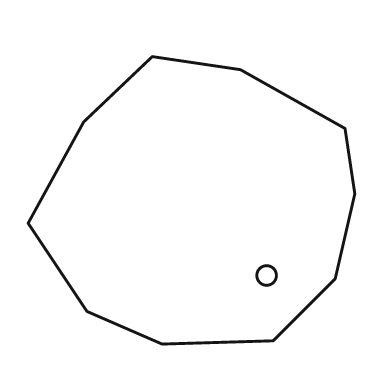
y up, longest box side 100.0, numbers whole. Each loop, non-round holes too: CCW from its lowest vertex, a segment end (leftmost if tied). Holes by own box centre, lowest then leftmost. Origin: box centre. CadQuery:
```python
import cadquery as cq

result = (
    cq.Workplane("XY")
    .moveTo(-9.0, -44.0)
    .lineTo(25.0, -43.0)
    .lineTo(44.0, -24.0)
    .lineTo(50.0, 2.0)
    .lineTo(47.0, 22.0)
    .lineTo(15.0, 40.0)
    .lineTo(-12.0, 44.0)
    .lineTo(-33.0, 24.0)
    .lineTo(-50.0, -7.0)
    .lineTo(-32.0, -34.0)
    .close()
    .moveTo(23.0, -23.0)
    .circle(3.0)
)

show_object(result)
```